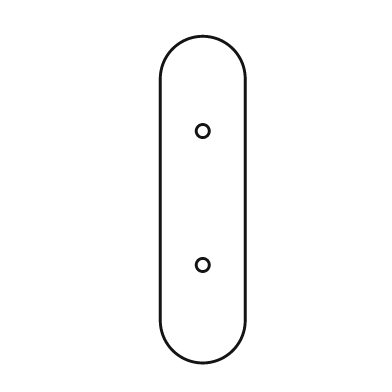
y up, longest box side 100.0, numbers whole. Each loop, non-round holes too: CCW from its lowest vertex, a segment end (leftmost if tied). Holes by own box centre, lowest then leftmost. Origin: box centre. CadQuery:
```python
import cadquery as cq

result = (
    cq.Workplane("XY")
    .moveTo(-13.0, -37.0)
    .threePointArc((0.0, -50.0), (13.0, -37.0))
    .lineTo(13.0, 37.0)
    .threePointArc((0.0, 50.0), (-13.0, 37.0))
    .close()
    .moveTo(0.0, -20.0)
    .circle(2.0)
    .moveTo(0.0, 21.0)
    .circle(2.0)
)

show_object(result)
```